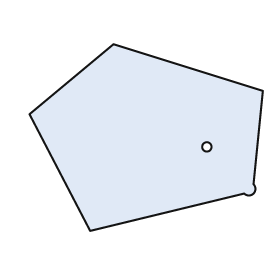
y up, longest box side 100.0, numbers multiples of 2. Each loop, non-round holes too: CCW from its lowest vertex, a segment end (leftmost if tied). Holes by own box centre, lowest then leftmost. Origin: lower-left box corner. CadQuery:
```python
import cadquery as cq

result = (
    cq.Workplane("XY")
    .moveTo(26.0, 0.0)
    .lineTo(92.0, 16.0)
    .threePointArc((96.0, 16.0), (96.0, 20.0))
    .lineTo(100.0, 60.0)
    .lineTo(36.0, 80.0)
    .lineTo(0.0, 50.0)
    .close()
    .moveTo(76.0, 36.0)
    .circle(2.0)
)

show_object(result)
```